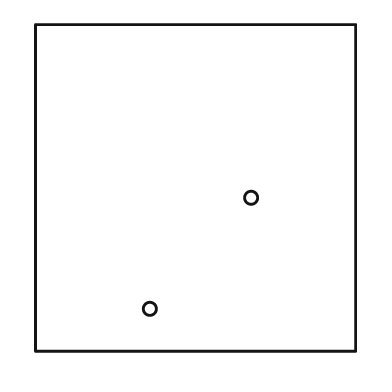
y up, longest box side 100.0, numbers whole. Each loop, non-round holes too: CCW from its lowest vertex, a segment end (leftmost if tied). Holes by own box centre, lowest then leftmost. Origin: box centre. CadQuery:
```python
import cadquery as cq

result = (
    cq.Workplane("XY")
    .moveTo(-49.0, -50.0)
    .lineTo(49.0, -50.0)
    .lineTo(49.0, 50.0)
    .lineTo(-49.0, 50.0)
    .close()
    .moveTo(-14.0, -37.0)
    .circle(2.0)
    .moveTo(17.0, -3.0)
    .circle(2.0)
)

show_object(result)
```